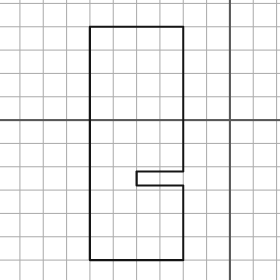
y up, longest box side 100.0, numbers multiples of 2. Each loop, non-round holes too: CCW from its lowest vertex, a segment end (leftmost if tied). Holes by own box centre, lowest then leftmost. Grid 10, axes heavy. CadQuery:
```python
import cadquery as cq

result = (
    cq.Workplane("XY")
    .moveTo(-60.0, -60.0)
    .lineTo(-20.0, -60.0)
    .lineTo(-20.0, -28.0)
    .lineTo(-40.0, -28.0)
    .lineTo(-40.0, -22.0)
    .lineTo(-20.0, -22.0)
    .lineTo(-20.0, 40.0)
    .lineTo(-60.0, 40.0)
    .close()
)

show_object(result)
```